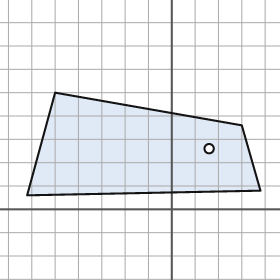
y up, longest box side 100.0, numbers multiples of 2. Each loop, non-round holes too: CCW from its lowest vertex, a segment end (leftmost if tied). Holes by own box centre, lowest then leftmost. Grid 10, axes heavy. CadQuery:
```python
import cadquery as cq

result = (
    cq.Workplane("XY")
    .moveTo(-62.0, 6.0)
    .lineTo(38.0, 8.0)
    .lineTo(30.0, 36.0)
    .lineTo(-50.0, 50.0)
    .close()
    .moveTo(16.0, 26.0)
    .circle(2.0)
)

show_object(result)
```